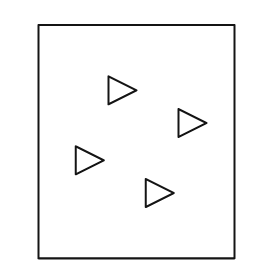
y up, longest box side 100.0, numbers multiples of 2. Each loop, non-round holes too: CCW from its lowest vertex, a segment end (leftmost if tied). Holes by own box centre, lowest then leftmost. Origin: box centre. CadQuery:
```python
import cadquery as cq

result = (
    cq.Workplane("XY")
    .moveTo(-42.0, -50.0)
    .lineTo(42.0, -50.0)
    .lineTo(42.0, 50.0)
    .lineTo(-42.0, 50.0)
    .close()
    .moveTo(4.0, -28.0)
    .lineTo(16.0, -22.0)
    .lineTo(4.0, -16.0)
    .close()
    .moveTo(-26.0, -14.0)
    .lineTo(-14.0, -8.0)
    .lineTo(-26.0, -2.0)
    .close()
    .moveTo(18.0, 2.0)
    .lineTo(30.0, 8.0)
    .lineTo(18.0, 14.0)
    .close()
    .moveTo(-12.0, 16.0)
    .lineTo(0.0, 22.0)
    .lineTo(-12.0, 28.0)
    .close()
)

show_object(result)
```